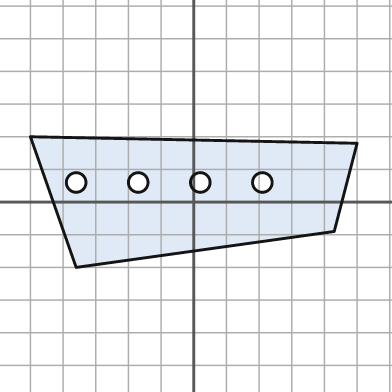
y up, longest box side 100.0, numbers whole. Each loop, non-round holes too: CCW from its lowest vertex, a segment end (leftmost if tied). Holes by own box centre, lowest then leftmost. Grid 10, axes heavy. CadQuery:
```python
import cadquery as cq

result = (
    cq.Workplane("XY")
    .moveTo(-36.0, -20.0)
    .lineTo(43.0, -9.0)
    .lineTo(50.0, 18.0)
    .lineTo(-50.0, 20.0)
    .close()
    .moveTo(-36.0, 6.0)
    .circle(3.0)
    .moveTo(-17.0, 6.0)
    .circle(3.0)
    .moveTo(2.0, 6.0)
    .circle(3.0)
    .moveTo(21.0, 6.0)
    .circle(3.0)
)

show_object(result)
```